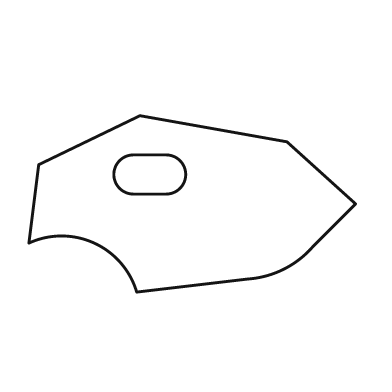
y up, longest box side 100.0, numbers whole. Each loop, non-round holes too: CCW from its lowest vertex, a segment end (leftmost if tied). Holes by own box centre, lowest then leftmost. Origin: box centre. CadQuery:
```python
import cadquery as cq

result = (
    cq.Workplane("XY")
    .moveTo(-17.0, -27.0)
    .lineTo(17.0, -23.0)
    .threePointArc((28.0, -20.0), (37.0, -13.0))
    .lineTo(50.0, 0.0)
    .lineTo(29.0, 19.0)
    .lineTo(-16.0, 27.0)
    .lineTo(-47.0, 12.0)
    .lineTo(-50.0, -12.0)
    .threePointArc((-30.0, -12.0), (-17.0, -27.0))
    .close()
    .moveTo(-18.0, 3.0)
    .lineTo(-8.0, 3.0)
    .threePointArc((-2.0, 9.0), (-8.0, 15.0))
    .lineTo(-18.0, 15.0)
    .threePointArc((-24.0, 9.0), (-18.0, 3.0))
    .close()
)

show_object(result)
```